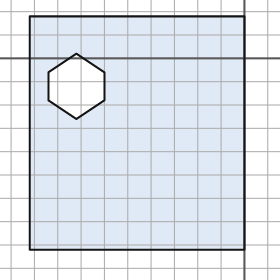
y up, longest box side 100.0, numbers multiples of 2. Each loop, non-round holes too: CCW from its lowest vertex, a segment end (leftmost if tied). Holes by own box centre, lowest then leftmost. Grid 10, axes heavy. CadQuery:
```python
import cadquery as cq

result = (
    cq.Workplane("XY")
    .moveTo(-92.0, -82.0)
    .lineTo(0.0, -82.0)
    .lineTo(0.0, 18.0)
    .lineTo(-92.0, 18.0)
    .close()
    .moveTo(-72.0, -26.0)
    .lineTo(-60.0, -18.0)
    .lineTo(-60.0, -6.0)
    .lineTo(-72.0, 2.0)
    .lineTo(-84.0, -6.0)
    .lineTo(-84.0, -18.0)
    .close()
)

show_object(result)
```